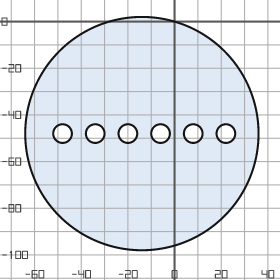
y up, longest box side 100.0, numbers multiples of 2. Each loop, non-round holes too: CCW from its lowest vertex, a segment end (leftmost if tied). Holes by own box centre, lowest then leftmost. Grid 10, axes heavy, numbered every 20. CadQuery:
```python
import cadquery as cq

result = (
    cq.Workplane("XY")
    .moveTo(-14.0, -48.0)
    .circle(50.0)
    .moveTo(-48.0, -48.0)
    .circle(4.0)
    .moveTo(-34.0, -48.0)
    .circle(4.0)
    .moveTo(-20.0, -48.0)
    .circle(4.0)
    .moveTo(-6.0, -48.0)
    .circle(4.0)
    .moveTo(8.0, -48.0)
    .circle(4.0)
    .moveTo(22.0, -48.0)
    .circle(4.0)
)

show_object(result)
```